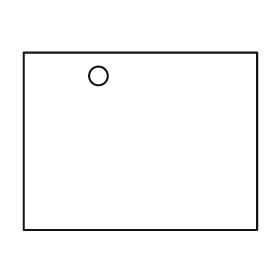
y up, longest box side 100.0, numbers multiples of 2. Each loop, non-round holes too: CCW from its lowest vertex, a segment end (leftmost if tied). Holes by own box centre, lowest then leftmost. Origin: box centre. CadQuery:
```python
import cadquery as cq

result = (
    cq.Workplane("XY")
    .moveTo(-50.0, -38.0)
    .lineTo(50.0, -38.0)
    .lineTo(50.0, 38.0)
    .lineTo(-50.0, 38.0)
    .close()
    .moveTo(-18.0, 28.0)
    .circle(4.0)
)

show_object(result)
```